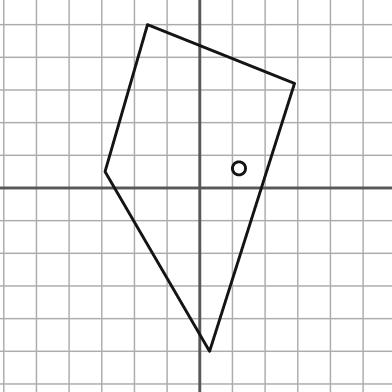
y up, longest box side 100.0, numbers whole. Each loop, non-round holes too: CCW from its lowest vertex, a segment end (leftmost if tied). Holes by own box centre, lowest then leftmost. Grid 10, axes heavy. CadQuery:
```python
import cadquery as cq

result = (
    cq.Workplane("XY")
    .moveTo(3.0, -50.0)
    .lineTo(29.0, 32.0)
    .lineTo(-16.0, 50.0)
    .lineTo(-29.0, 5.0)
    .close()
    .moveTo(12.0, 6.0)
    .circle(2.0)
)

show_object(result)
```